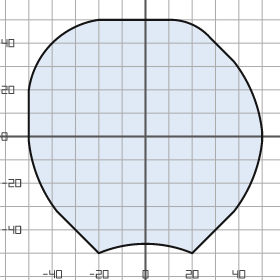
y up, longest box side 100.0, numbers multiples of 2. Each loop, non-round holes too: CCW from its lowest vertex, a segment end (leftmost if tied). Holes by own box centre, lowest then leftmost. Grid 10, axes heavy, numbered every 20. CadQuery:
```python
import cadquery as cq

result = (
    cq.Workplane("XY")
    .moveTo(-20.0, -50.0)
    .threePointArc((0.0, -46.0), (20.0, -50.0))
    .lineTo(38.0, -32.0)
    .threePointArc((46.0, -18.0), (50.0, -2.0))
    .lineTo(50.0, 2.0)
    .threePointArc((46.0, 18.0), (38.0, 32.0))
    .lineTo(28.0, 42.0)
    .threePointArc((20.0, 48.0), (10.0, 50.0))
    .lineTo(-20.0, 50.0)
    .threePointArc((-40.0, 40.0), (-50.0, 20.0))
    .lineTo(-50.0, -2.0)
    .threePointArc((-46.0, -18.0), (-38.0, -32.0))
    .close()
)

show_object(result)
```